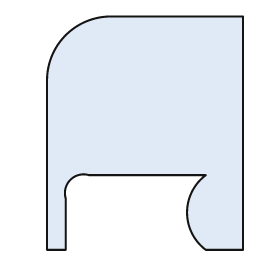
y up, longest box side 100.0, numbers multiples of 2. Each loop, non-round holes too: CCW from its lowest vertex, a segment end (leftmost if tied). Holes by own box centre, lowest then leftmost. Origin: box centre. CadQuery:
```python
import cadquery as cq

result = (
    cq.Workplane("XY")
    .moveTo(-42.0, -50.0)
    .lineTo(-34.0, -50.0)
    .lineTo(-34.0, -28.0)
    .threePointArc((-32.0, -20.0), (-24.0, -18.0))
    .lineTo(26.0, -18.0)
    .threePointArc((18.0, -34.0), (26.0, -50.0))
    .lineTo(42.0, -50.0)
    .lineTo(42.0, 50.0)
    .lineTo(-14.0, 50.0)
    .threePointArc((-34.0, 42.0), (-42.0, 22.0))
    .close()
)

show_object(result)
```